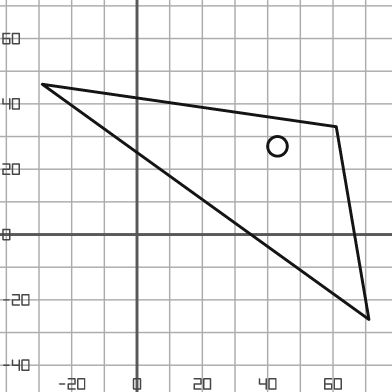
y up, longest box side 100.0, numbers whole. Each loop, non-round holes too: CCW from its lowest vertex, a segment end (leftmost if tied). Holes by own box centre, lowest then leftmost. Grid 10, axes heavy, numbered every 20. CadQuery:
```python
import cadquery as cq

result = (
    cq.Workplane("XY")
    .moveTo(71.0, -26.0)
    .lineTo(61.0, 33.0)
    .lineTo(-29.0, 46.0)
    .close()
    .moveTo(43.0, 27.0)
    .circle(3.0)
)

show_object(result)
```